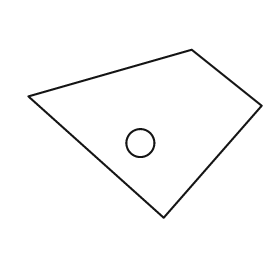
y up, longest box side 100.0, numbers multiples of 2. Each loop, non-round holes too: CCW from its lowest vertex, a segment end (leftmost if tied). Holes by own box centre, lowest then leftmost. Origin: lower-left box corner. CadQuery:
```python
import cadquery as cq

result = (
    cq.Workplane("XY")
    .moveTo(58.0, 0.0)
    .lineTo(100.0, 48.0)
    .lineTo(70.0, 72.0)
    .lineTo(0.0, 52.0)
    .close()
    .moveTo(48.0, 32.0)
    .circle(6.0)
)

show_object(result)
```